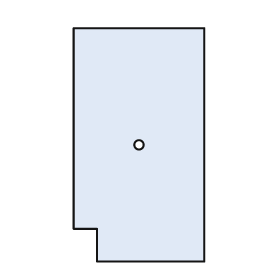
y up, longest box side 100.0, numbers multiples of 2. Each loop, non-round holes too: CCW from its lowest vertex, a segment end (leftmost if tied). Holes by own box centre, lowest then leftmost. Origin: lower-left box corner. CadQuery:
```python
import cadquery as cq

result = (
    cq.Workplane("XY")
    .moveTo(10.0, 0.0)
    .lineTo(56.0, 0.0)
    .lineTo(56.0, 100.0)
    .lineTo(0.0, 100.0)
    .lineTo(0.0, 14.0)
    .lineTo(10.0, 14.0)
    .close()
    .moveTo(28.0, 50.0)
    .circle(2.0)
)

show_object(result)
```